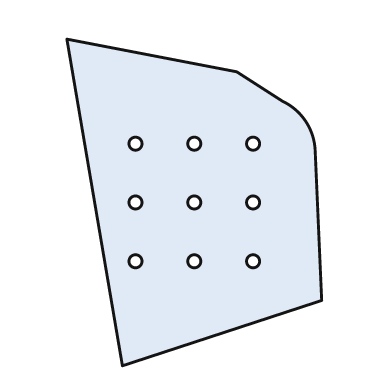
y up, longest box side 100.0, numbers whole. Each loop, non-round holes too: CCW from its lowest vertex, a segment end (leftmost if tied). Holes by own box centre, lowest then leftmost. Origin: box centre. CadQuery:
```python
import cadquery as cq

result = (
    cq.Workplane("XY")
    .moveTo(-22.0, -50.0)
    .lineTo(39.0, -30.0)
    .lineTo(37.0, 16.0)
    .threePointArc((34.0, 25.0), (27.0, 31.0))
    .lineTo(13.0, 40.0)
    .lineTo(-39.0, 50.0)
    .close()
    .moveTo(-18.0, -18.0)
    .circle(2.0)
    .moveTo(0.0, -18.0)
    .circle(2.0)
    .moveTo(18.0, -18.0)
    .circle(2.0)
    .moveTo(-18.0, 0.0)
    .circle(2.0)
    .moveTo(0.0, 0.0)
    .circle(2.0)
    .moveTo(18.0, 0.0)
    .circle(2.0)
    .moveTo(-18.0, 18.0)
    .circle(2.0)
    .moveTo(0.0, 18.0)
    .circle(2.0)
    .moveTo(18.0, 18.0)
    .circle(2.0)
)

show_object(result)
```